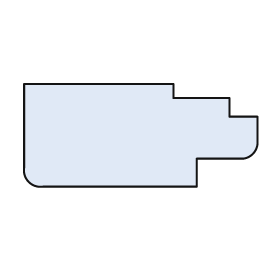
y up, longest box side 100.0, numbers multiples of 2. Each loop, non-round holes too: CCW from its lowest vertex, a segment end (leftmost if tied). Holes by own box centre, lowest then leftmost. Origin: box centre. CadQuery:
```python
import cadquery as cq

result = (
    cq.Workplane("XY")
    .moveTo(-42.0, -22.0)
    .lineTo(24.0, -22.0)
    .lineTo(24.0, -10.0)
    .lineTo(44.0, -10.0)
    .threePointArc((48.0, -8.0), (50.0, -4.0))
    .lineTo(50.0, 8.0)
    .lineTo(38.0, 8.0)
    .lineTo(38.0, 16.0)
    .lineTo(14.0, 16.0)
    .lineTo(14.0, 22.0)
    .lineTo(-50.0, 22.0)
    .lineTo(-50.0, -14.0)
    .threePointArc((-48.0, -20.0), (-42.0, -22.0))
    .close()
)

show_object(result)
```